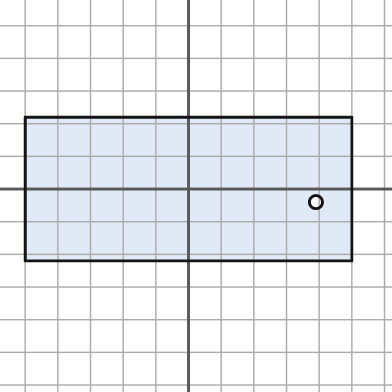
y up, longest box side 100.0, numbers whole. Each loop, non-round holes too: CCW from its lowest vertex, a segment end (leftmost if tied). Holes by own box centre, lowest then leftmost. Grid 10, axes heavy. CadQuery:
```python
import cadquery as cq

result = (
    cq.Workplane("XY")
    .moveTo(-50.0, -22.0)
    .lineTo(50.0, -22.0)
    .lineTo(50.0, 22.0)
    .lineTo(-50.0, 22.0)
    .close()
    .moveTo(39.0, -4.0)
    .circle(2.0)
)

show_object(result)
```